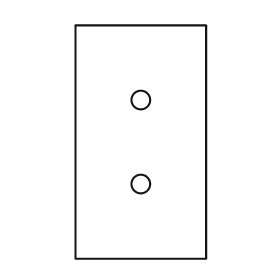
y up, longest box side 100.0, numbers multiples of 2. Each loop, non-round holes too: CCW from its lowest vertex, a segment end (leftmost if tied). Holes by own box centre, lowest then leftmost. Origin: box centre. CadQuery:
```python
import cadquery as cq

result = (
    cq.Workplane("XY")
    .moveTo(-28.0, -50.0)
    .lineTo(28.0, -50.0)
    .lineTo(28.0, 50.0)
    .lineTo(-28.0, 50.0)
    .close()
    .moveTo(0.0, -18.0)
    .circle(4.0)
    .moveTo(0.0, 18.0)
    .circle(4.0)
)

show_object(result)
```